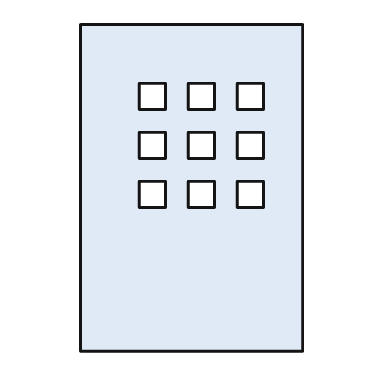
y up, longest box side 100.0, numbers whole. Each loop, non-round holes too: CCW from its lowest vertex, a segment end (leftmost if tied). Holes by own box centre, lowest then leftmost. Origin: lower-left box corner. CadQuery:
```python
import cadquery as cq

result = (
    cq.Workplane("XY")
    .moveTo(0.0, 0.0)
    .lineTo(68.0, 0.0)
    .lineTo(68.0, 100.0)
    .lineTo(0.0, 100.0)
    .close()
    .moveTo(18.0, 44.0)
    .lineTo(26.0, 44.0)
    .lineTo(26.0, 52.0)
    .lineTo(18.0, 52.0)
    .close()
    .moveTo(33.0, 44.0)
    .lineTo(41.0, 44.0)
    .lineTo(41.0, 52.0)
    .lineTo(33.0, 52.0)
    .close()
    .moveTo(48.0, 44.0)
    .lineTo(56.0, 44.0)
    .lineTo(56.0, 52.0)
    .lineTo(48.0, 52.0)
    .close()
    .moveTo(18.0, 59.0)
    .lineTo(26.0, 59.0)
    .lineTo(26.0, 67.0)
    .lineTo(18.0, 67.0)
    .close()
    .moveTo(33.0, 59.0)
    .lineTo(41.0, 59.0)
    .lineTo(41.0, 67.0)
    .lineTo(33.0, 67.0)
    .close()
    .moveTo(48.0, 59.0)
    .lineTo(56.0, 59.0)
    .lineTo(56.0, 67.0)
    .lineTo(48.0, 67.0)
    .close()
    .moveTo(18.0, 74.0)
    .lineTo(26.0, 74.0)
    .lineTo(26.0, 82.0)
    .lineTo(18.0, 82.0)
    .close()
    .moveTo(33.0, 74.0)
    .lineTo(41.0, 74.0)
    .lineTo(41.0, 82.0)
    .lineTo(33.0, 82.0)
    .close()
    .moveTo(48.0, 74.0)
    .lineTo(56.0, 74.0)
    .lineTo(56.0, 82.0)
    .lineTo(48.0, 82.0)
    .close()
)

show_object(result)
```